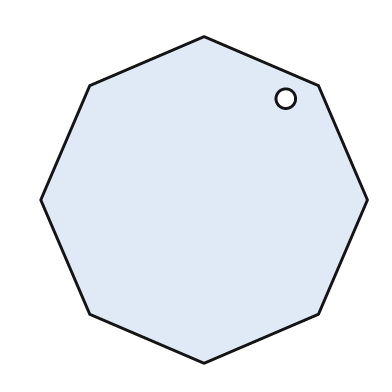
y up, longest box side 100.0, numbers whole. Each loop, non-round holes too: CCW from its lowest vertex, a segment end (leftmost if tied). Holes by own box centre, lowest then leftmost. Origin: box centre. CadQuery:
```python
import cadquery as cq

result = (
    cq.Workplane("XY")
    .moveTo(0.0, -50.0)
    .lineTo(35.0, -35.0)
    .lineTo(50.0, 0.0)
    .lineTo(35.0, 35.0)
    .lineTo(0.0, 50.0)
    .lineTo(-35.0, 35.0)
    .lineTo(-50.0, 0.0)
    .lineTo(-35.0, -35.0)
    .close()
    .moveTo(25.0, 31.0)
    .circle(3.0)
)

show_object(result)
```